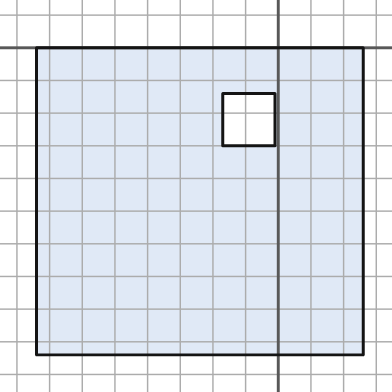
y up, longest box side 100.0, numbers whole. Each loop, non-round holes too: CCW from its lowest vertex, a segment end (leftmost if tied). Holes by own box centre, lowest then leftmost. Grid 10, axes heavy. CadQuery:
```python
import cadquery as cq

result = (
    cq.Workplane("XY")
    .moveTo(-74.0, -94.0)
    .lineTo(26.0, -94.0)
    .lineTo(26.0, 0.0)
    .lineTo(-74.0, 0.0)
    .close()
    .moveTo(-17.0, -30.0)
    .lineTo(-1.0, -30.0)
    .lineTo(-1.0, -14.0)
    .lineTo(-17.0, -14.0)
    .close()
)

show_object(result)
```